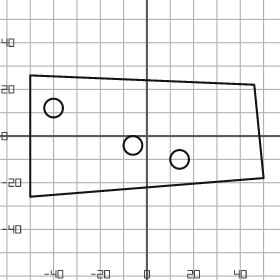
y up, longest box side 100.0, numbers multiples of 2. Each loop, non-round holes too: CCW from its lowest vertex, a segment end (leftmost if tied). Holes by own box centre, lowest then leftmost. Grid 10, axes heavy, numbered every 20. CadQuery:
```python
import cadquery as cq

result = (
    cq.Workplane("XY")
    .moveTo(-50.0, -26.0)
    .lineTo(50.0, -18.0)
    .lineTo(46.0, 22.0)
    .lineTo(-50.0, 26.0)
    .close()
    .moveTo(14.0, -10.0)
    .circle(4.0)
    .moveTo(-6.0, -4.0)
    .circle(4.0)
    .moveTo(-40.0, 12.0)
    .circle(4.0)
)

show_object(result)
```